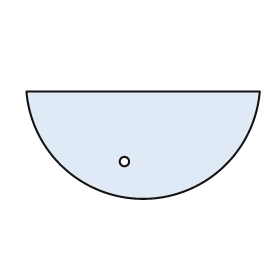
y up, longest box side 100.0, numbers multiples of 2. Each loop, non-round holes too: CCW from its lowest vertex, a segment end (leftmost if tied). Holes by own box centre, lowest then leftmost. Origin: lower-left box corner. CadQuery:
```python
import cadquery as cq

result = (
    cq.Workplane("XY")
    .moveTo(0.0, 46.0)
    .threePointArc((50.0, 0.0), (100.0, 46.0))
    .close()
    .moveTo(42.0, 16.0)
    .circle(2.0)
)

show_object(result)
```